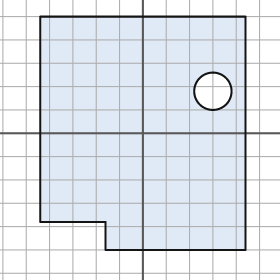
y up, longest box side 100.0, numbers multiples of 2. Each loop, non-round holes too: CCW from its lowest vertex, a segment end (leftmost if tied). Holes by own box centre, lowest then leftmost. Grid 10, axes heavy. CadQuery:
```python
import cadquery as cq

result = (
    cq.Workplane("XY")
    .moveTo(-16.0, -50.0)
    .lineTo(44.0, -50.0)
    .lineTo(44.0, 50.0)
    .lineTo(-44.0, 50.0)
    .lineTo(-44.0, -38.0)
    .lineTo(-16.0, -38.0)
    .close()
    .moveTo(30.0, 18.0)
    .circle(8.0)
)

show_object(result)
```